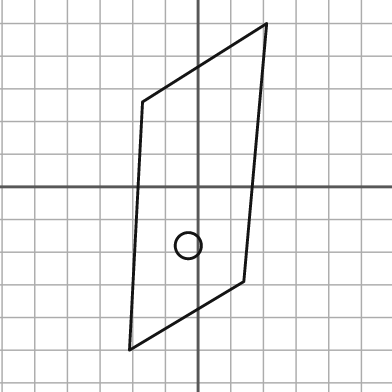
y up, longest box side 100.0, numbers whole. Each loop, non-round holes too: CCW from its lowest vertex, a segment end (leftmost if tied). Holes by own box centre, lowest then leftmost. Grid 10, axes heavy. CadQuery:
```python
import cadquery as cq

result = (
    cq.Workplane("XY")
    .moveTo(-21.0, -50.0)
    .lineTo(14.0, -29.0)
    .lineTo(21.0, 50.0)
    .lineTo(-17.0, 26.0)
    .close()
    .moveTo(-3.0, -18.0)
    .circle(4.0)
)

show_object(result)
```